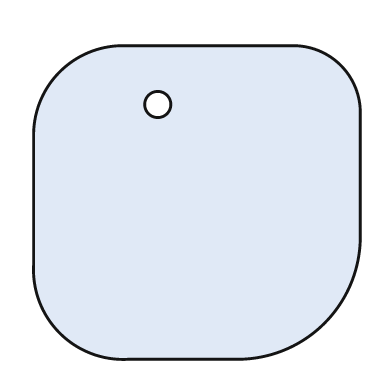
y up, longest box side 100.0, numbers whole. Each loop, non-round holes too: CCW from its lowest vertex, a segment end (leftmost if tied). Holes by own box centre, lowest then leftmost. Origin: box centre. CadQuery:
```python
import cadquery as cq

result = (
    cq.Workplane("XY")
    .moveTo(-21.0, -48.0)
    .lineTo(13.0, -48.0)
    .threePointArc((39.0, -37.0), (50.0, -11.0))
    .lineTo(50.0, 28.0)
    .threePointArc((44.0, 42.0), (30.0, 48.0))
    .lineTo(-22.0, 48.0)
    .threePointArc((-42.0, 40.0), (-50.0, 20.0))
    .lineTo(-50.0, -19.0)
    .threePointArc((-42.0, -40.0), (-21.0, -48.0))
    .close()
    .moveTo(-12.0, 30.0)
    .circle(4.0)
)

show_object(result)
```